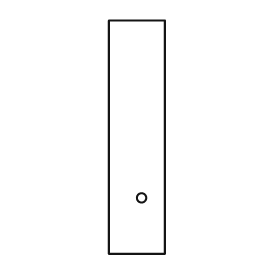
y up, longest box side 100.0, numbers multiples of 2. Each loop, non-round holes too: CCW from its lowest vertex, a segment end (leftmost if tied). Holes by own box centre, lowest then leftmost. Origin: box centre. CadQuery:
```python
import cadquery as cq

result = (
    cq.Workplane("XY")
    .moveTo(-12.0, -50.0)
    .lineTo(12.0, -50.0)
    .lineTo(12.0, 50.0)
    .lineTo(-12.0, 50.0)
    .close()
    .moveTo(2.0, -26.0)
    .circle(2.0)
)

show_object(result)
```